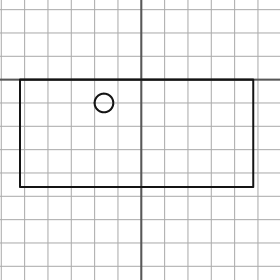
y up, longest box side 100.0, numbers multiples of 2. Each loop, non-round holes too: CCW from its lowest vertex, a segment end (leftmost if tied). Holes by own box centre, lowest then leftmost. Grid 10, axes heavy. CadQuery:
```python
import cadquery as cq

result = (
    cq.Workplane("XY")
    .moveTo(-52.0, -46.0)
    .lineTo(48.0, -46.0)
    .lineTo(48.0, 0.0)
    .lineTo(-52.0, 0.0)
    .close()
    .moveTo(-16.0, -10.0)
    .circle(4.0)
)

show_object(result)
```